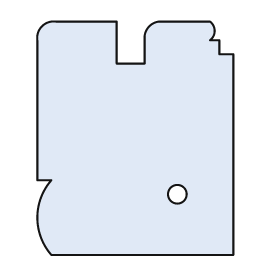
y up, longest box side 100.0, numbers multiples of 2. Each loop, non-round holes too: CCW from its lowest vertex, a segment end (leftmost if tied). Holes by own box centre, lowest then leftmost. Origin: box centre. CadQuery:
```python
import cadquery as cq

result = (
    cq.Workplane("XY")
    .moveTo(-36.0, -50.0)
    .lineTo(42.0, -50.0)
    .lineTo(42.0, 36.0)
    .lineTo(36.0, 36.0)
    .lineTo(36.0, 42.0)
    .lineTo(32.0, 42.0)
    .threePointArc((34.0, 46.0), (32.0, 50.0))
    .lineTo(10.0, 50.0)
    .threePointArc((6.0, 48.0), (4.0, 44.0))
    .lineTo(4.0, 32.0)
    .lineTo(-8.0, 32.0)
    .lineTo(-8.0, 50.0)
    .lineTo(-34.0, 50.0)
    .threePointArc((-40.0, 48.0), (-42.0, 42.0))
    .lineTo(-42.0, -18.0)
    .lineTo(-36.0, -18.0)
    .threePointArc((-42.0, -34.0), (-36.0, -50.0))
    .close()
    .moveTo(18.0, -24.0)
    .circle(4.0)
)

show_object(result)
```